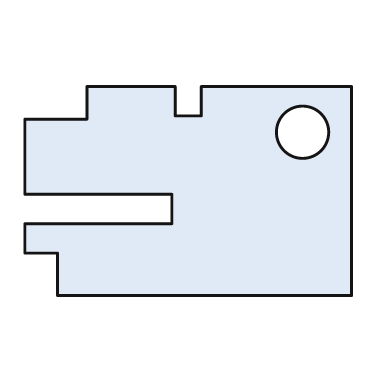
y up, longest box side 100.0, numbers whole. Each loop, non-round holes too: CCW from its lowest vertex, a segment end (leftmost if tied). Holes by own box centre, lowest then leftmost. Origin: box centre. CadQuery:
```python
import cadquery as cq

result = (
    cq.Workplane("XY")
    .moveTo(-40.0, -32.0)
    .lineTo(50.0, -32.0)
    .lineTo(50.0, 32.0)
    .lineTo(4.0, 32.0)
    .lineTo(4.0, 23.0)
    .lineTo(-4.0, 23.0)
    .lineTo(-4.0, 32.0)
    .lineTo(-31.0, 32.0)
    .lineTo(-31.0, 22.0)
    .lineTo(-50.0, 22.0)
    .lineTo(-50.0, -1.0)
    .lineTo(-5.0, -1.0)
    .lineTo(-5.0, -10.0)
    .lineTo(-50.0, -10.0)
    .lineTo(-50.0, -19.0)
    .lineTo(-40.0, -19.0)
    .close()
    .moveTo(35.0, 18.0)
    .circle(8.0)
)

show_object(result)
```